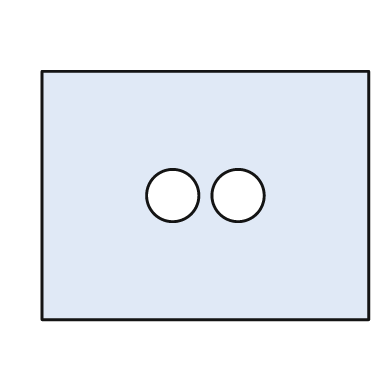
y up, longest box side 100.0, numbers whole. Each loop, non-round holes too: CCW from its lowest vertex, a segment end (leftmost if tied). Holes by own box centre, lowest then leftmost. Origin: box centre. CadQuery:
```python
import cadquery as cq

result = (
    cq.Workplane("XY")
    .moveTo(-50.0, -38.0)
    .lineTo(50.0, -38.0)
    .lineTo(50.0, 38.0)
    .lineTo(-50.0, 38.0)
    .close()
    .moveTo(-10.0, 0.0)
    .circle(8.0)
    .moveTo(10.0, 0.0)
    .circle(8.0)
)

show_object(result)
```